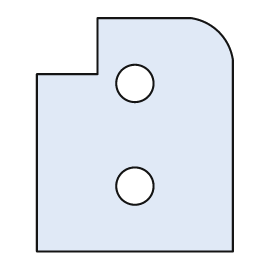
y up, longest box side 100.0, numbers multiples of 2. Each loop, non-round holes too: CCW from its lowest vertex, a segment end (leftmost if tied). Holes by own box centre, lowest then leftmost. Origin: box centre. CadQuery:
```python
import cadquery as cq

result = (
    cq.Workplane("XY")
    .moveTo(-42.0, -50.0)
    .lineTo(42.0, -50.0)
    .lineTo(42.0, 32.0)
    .threePointArc((36.0, 44.0), (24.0, 50.0))
    .lineTo(-16.0, 50.0)
    .lineTo(-16.0, 26.0)
    .lineTo(-42.0, 26.0)
    .close()
    .moveTo(0.0, -22.0)
    .circle(8.0)
    .moveTo(0.0, 22.0)
    .circle(8.0)
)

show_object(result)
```